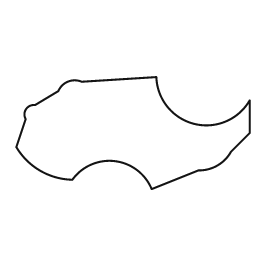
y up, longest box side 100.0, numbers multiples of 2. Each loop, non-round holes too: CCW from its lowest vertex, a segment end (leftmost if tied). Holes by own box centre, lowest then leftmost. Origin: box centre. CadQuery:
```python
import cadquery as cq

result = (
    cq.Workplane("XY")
    .moveTo(8.0, -24.0)
    .lineTo(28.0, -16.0)
    .threePointArc((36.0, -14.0), (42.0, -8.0))
    .lineTo(50.0, 0.0)
    .lineTo(50.0, 14.0)
    .threePointArc((26.0, 4.0), (10.0, 24.0))
    .lineTo(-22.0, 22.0)
    .threePointArc((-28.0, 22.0), (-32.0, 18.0))
    .lineTo(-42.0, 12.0)
    .threePointArc((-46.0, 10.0), (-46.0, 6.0))
    .lineTo(-50.0, -6.0)
    .threePointArc((-40.0, -16.0), (-26.0, -20.0))
    .threePointArc((-8.0, -12.0), (8.0, -24.0))
    .close()
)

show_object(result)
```